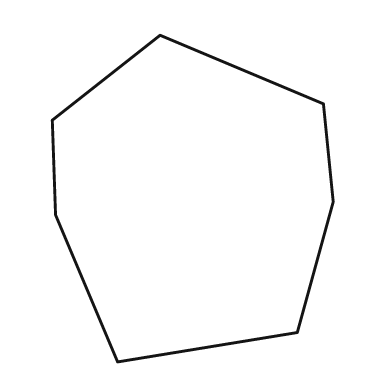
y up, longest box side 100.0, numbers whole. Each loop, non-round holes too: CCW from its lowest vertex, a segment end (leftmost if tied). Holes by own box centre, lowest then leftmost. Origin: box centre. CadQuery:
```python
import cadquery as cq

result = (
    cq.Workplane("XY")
    .moveTo(-23.0, -50.0)
    .lineTo(32.0, -41.0)
    .lineTo(43.0, -1.0)
    .lineTo(40.0, 29.0)
    .lineTo(-10.0, 50.0)
    .lineTo(-43.0, 24.0)
    .lineTo(-42.0, -5.0)
    .close()
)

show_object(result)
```